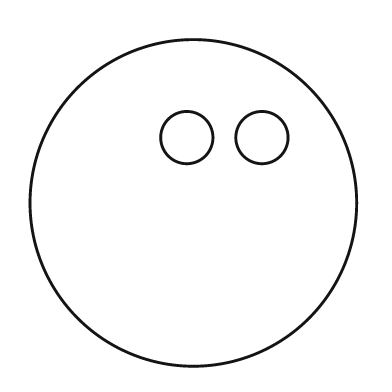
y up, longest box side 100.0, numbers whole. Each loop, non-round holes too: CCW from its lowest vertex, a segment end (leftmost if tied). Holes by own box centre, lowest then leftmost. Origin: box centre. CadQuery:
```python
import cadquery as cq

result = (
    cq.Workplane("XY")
    .moveTo(0.0, 0.0)
    .circle(50.0)
    .moveTo(-2.0, 20.0)
    .circle(8.0)
    .moveTo(21.0, 20.0)
    .circle(8.0)
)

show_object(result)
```